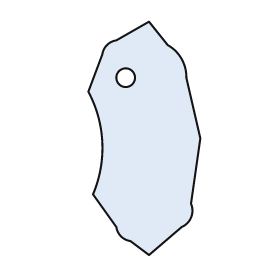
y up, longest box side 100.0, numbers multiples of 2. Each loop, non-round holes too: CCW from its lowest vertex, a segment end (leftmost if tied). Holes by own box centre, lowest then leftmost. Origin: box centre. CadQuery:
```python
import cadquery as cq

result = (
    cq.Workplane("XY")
    .moveTo(2.0, -50.0)
    .lineTo(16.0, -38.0)
    .threePointArc((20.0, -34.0), (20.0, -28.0))
    .lineTo(24.0, 0.0)
    .lineTo(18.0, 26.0)
    .threePointArc((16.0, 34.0), (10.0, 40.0))
    .lineTo(2.0, 50.0)
    .lineTo(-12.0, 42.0)
    .threePointArc((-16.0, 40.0), (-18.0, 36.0))
    .lineTo(-24.0, 20.0)
    .threePointArc((-18.0, -2.0), (-22.0, -24.0))
    .lineTo(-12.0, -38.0)
    .threePointArc((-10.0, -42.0), (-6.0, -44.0))
    .close()
    .moveTo(-8.0, 26.0)
    .circle(4.0)
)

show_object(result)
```